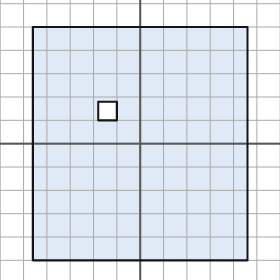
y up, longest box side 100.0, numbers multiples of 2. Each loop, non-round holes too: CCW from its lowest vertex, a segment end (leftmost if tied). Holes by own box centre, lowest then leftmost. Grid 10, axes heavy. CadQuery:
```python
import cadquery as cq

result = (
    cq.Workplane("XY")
    .moveTo(-46.0, -50.0)
    .lineTo(46.0, -50.0)
    .lineTo(46.0, 50.0)
    .lineTo(-46.0, 50.0)
    .close()
    .moveTo(-18.0, 10.0)
    .lineTo(-10.0, 10.0)
    .lineTo(-10.0, 18.0)
    .lineTo(-18.0, 18.0)
    .close()
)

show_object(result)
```